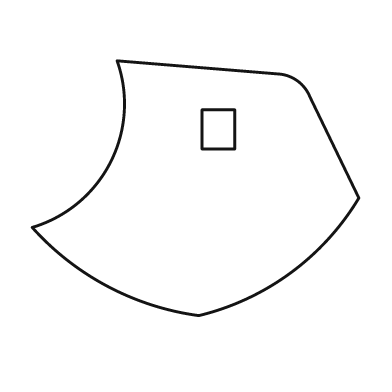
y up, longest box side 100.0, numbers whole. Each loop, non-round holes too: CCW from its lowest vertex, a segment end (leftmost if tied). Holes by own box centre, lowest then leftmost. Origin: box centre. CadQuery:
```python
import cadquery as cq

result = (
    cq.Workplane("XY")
    .moveTo(1.0, -39.0)
    .threePointArc((29.0, -26.0), (50.0, -3.0))
    .lineTo(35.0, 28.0)
    .threePointArc((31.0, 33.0), (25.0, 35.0))
    .lineTo(-24.0, 39.0)
    .threePointArc((-26.0, 8.0), (-50.0, -12.0))
    .threePointArc((-27.0, -30.0), (1.0, -39.0))
    .close()
    .moveTo(2.0, 12.0)
    .lineTo(12.0, 12.0)
    .lineTo(12.0, 24.0)
    .lineTo(2.0, 24.0)
    .close()
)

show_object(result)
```